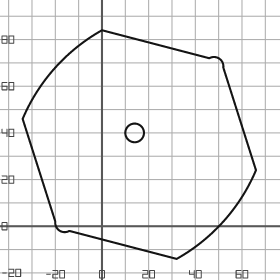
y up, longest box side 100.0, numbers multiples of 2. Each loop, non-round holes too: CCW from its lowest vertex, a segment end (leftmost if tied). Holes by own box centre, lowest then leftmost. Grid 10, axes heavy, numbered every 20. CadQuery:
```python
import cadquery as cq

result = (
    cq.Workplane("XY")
    .moveTo(32.0, -14.0)
    .threePointArc((52.0, 2.0), (66.0, 24.0))
    .lineTo(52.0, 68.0)
    .threePointArc((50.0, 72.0), (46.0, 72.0))
    .lineTo(0.0, 84.0)
    .threePointArc((-20.0, 68.0), (-34.0, 46.0))
    .lineTo(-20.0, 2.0)
    .threePointArc((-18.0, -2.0), (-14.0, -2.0))
    .close()
    .moveTo(14.0, 40.0)
    .circle(4.0)
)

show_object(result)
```